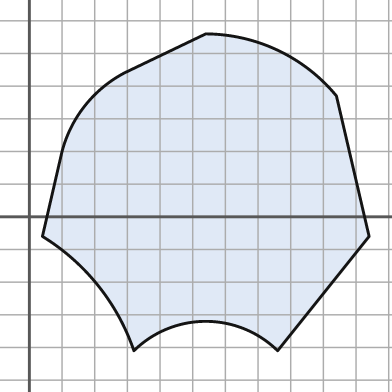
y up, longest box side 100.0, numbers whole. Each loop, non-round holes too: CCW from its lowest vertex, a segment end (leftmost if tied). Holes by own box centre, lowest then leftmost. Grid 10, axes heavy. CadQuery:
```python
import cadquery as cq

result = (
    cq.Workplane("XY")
    .moveTo(32.0, -41.0)
    .threePointArc((54.0, -32.0), (76.0, -41.0))
    .lineTo(104.0, -6.0)
    .lineTo(94.0, 37.0)
    .threePointArc((76.0, 51.0), (54.0, 56.0))
    .lineTo(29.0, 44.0)
    .threePointArc((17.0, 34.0), (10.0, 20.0))
    .lineTo(4.0, -6.0)
    .threePointArc((21.0, -21.0), (32.0, -41.0))
    .close()
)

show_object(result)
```